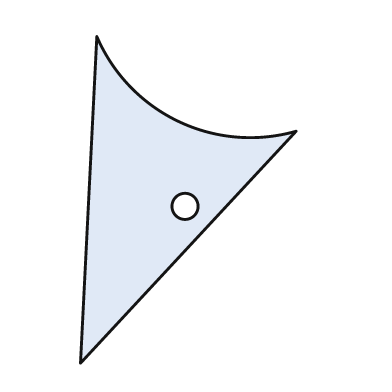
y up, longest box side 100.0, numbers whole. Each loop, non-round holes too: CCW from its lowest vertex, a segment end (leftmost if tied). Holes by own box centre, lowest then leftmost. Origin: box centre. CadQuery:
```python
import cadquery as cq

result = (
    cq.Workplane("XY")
    .moveTo(-33.0, -50.0)
    .lineTo(33.0, 21.0)
    .threePointArc((-3.0, 24.0), (-28.0, 50.0))
    .close()
    .moveTo(-1.0, -2.0)
    .circle(4.0)
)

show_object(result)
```